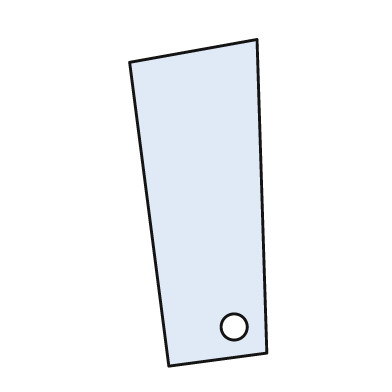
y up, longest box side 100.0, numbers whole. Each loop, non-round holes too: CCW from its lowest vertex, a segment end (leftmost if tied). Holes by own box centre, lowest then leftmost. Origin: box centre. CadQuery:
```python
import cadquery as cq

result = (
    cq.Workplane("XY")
    .moveTo(-9.0, -50.0)
    .lineTo(21.0, -46.0)
    .lineTo(18.0, 50.0)
    .lineTo(-21.0, 43.0)
    .close()
    .moveTo(11.0, -38.0)
    .circle(4.0)
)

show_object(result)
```